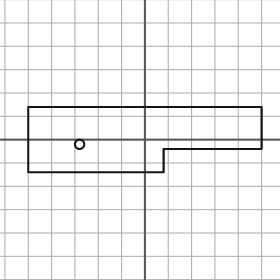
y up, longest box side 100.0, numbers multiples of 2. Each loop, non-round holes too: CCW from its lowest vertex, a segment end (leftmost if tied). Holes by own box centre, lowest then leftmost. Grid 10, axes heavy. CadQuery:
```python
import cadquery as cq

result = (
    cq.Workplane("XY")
    .moveTo(-50.0, -14.0)
    .lineTo(8.0, -14.0)
    .lineTo(8.0, -4.0)
    .lineTo(50.0, -4.0)
    .lineTo(50.0, 14.0)
    .lineTo(-50.0, 14.0)
    .close()
    .moveTo(-28.0, -2.0)
    .circle(2.0)
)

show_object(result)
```